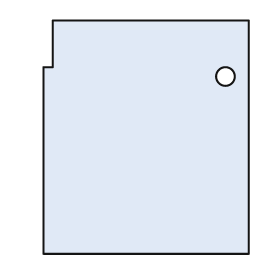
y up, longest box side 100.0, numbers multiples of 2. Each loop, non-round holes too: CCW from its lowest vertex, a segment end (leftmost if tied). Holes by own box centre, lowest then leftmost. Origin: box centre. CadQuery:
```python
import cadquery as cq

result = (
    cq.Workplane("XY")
    .moveTo(-44.0, -50.0)
    .lineTo(44.0, -50.0)
    .lineTo(44.0, 50.0)
    .lineTo(-40.0, 50.0)
    .lineTo(-40.0, 30.0)
    .lineTo(-44.0, 30.0)
    .close()
    .moveTo(34.0, 26.0)
    .circle(4.0)
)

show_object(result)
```